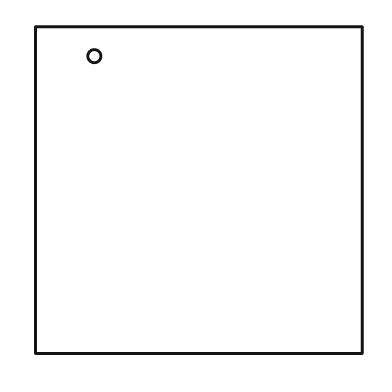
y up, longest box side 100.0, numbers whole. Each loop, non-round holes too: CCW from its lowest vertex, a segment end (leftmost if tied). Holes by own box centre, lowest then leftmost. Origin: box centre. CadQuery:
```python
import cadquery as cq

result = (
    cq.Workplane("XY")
    .moveTo(-50.0, -50.0)
    .lineTo(50.0, -50.0)
    .lineTo(50.0, 50.0)
    .lineTo(-50.0, 50.0)
    .close()
    .moveTo(-32.0, 41.0)
    .circle(2.0)
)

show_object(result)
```